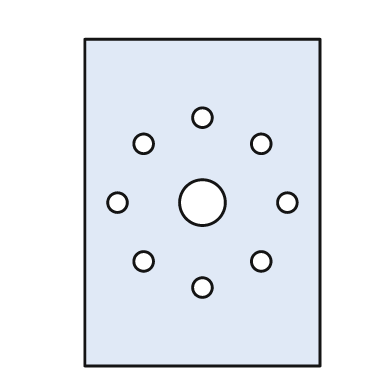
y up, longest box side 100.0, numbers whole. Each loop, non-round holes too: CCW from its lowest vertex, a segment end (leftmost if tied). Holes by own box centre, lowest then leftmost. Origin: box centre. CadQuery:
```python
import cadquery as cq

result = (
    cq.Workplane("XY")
    .moveTo(-36.0, -50.0)
    .lineTo(36.0, -50.0)
    .lineTo(36.0, 50.0)
    .lineTo(-36.0, 50.0)
    .close()
    .moveTo(0.0, -26.0)
    .circle(3.0)
    .moveTo(-18.0, -18.0)
    .circle(3.0)
    .moveTo(18.0, -18.0)
    .circle(3.0)
    .moveTo(-26.0, 0.0)
    .circle(3.0)
    .moveTo(0.0, 0.0)
    .circle(7.0)
    .moveTo(26.0, 0.0)
    .circle(3.0)
    .moveTo(-18.0, 18.0)
    .circle(3.0)
    .moveTo(18.0, 18.0)
    .circle(3.0)
    .moveTo(0.0, 26.0)
    .circle(3.0)
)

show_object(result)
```